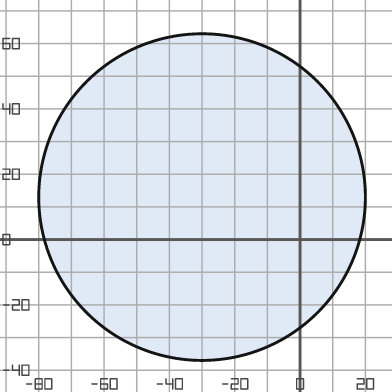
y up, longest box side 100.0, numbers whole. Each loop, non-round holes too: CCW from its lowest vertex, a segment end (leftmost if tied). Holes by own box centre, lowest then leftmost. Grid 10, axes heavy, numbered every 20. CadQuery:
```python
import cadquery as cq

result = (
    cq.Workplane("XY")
    .moveTo(-30.0, 13.0)
    .circle(50.0)
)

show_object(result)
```